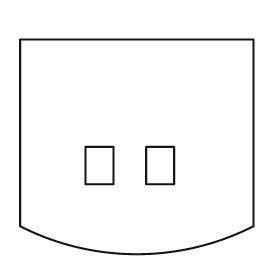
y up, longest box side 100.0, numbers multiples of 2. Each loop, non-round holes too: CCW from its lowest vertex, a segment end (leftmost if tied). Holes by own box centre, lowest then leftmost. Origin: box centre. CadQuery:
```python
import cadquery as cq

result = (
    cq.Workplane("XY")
    .moveTo(-50.0, -34.0)
    .threePointArc((0.0, -46.0), (50.0, -34.0))
    .lineTo(50.0, 46.0)
    .lineTo(-50.0, 46.0)
    .close()
    .moveTo(-22.0, -16.0)
    .lineTo(-10.0, -16.0)
    .lineTo(-10.0, 0.0)
    .lineTo(-22.0, 0.0)
    .close()
    .moveTo(4.0, -16.0)
    .lineTo(16.0, -16.0)
    .lineTo(16.0, 0.0)
    .lineTo(4.0, 0.0)
    .close()
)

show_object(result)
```